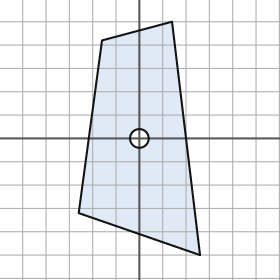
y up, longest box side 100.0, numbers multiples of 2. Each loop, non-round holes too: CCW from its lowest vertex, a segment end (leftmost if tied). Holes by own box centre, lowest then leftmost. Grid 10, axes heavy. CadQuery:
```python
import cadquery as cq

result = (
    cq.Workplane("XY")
    .moveTo(26.0, -50.0)
    .lineTo(14.0, 50.0)
    .lineTo(-16.0, 42.0)
    .lineTo(-26.0, -32.0)
    .close()
    .moveTo(0.0, 0.0)
    .circle(4.0)
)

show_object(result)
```